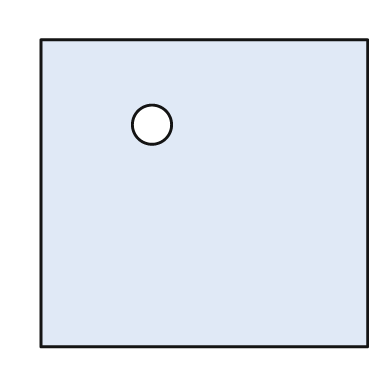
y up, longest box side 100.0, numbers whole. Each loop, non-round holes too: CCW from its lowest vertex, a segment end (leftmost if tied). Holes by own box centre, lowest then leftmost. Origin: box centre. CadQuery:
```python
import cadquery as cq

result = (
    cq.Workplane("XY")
    .moveTo(-50.0, -47.0)
    .lineTo(50.0, -47.0)
    .lineTo(50.0, 47.0)
    .lineTo(-50.0, 47.0)
    .close()
    .moveTo(-16.0, 21.0)
    .circle(6.0)
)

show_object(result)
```